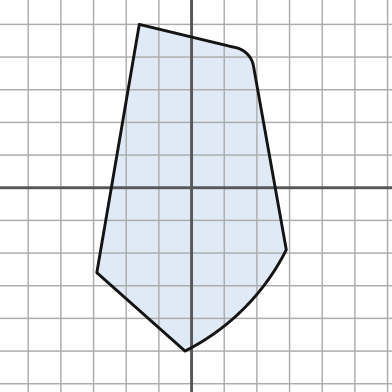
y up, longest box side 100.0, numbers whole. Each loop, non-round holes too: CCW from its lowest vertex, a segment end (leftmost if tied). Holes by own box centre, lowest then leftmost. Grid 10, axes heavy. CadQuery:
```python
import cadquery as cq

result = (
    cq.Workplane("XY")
    .moveTo(-2.0, -50.0)
    .threePointArc((16.0, -37.0), (29.0, -19.0))
    .lineTo(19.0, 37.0)
    .threePointArc((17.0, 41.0), (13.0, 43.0))
    .lineTo(-16.0, 50.0)
    .lineTo(-29.0, -26.0)
    .close()
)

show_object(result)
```